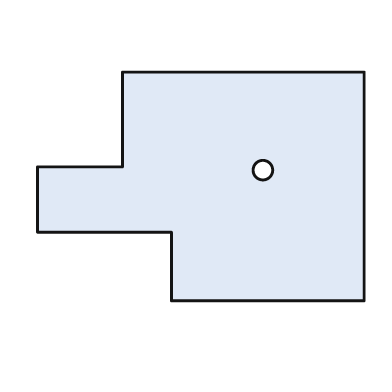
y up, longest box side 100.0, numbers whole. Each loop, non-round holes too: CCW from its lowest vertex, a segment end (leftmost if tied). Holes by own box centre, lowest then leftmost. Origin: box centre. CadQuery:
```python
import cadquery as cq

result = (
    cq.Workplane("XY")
    .moveTo(-9.0, -35.0)
    .lineTo(50.0, -35.0)
    .lineTo(50.0, 35.0)
    .lineTo(-24.0, 35.0)
    .lineTo(-24.0, 6.0)
    .lineTo(-50.0, 6.0)
    .lineTo(-50.0, -14.0)
    .lineTo(-9.0, -14.0)
    .close()
    .moveTo(19.0, 5.0)
    .circle(3.0)
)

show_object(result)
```